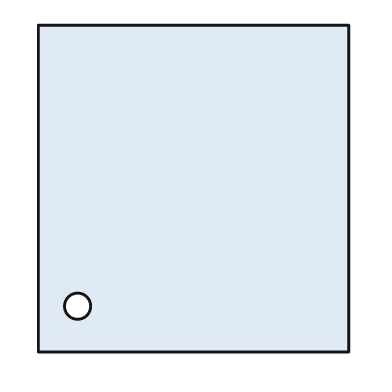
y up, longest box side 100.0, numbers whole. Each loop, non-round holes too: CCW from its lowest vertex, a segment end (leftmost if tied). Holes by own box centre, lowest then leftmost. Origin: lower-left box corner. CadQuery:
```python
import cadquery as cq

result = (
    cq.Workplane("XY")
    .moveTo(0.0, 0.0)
    .lineTo(95.0, 0.0)
    .lineTo(95.0, 100.0)
    .lineTo(0.0, 100.0)
    .close()
    .moveTo(12.0, 14.0)
    .circle(4.0)
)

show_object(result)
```